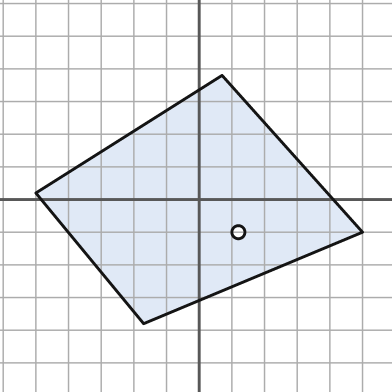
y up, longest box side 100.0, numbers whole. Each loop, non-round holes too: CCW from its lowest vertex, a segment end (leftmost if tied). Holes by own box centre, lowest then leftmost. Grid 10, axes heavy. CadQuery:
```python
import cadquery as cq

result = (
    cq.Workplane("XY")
    .moveTo(-17.0, -38.0)
    .lineTo(50.0, -10.0)
    .lineTo(7.0, 38.0)
    .lineTo(-50.0, 2.0)
    .close()
    .moveTo(12.0, -10.0)
    .circle(2.0)
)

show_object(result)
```